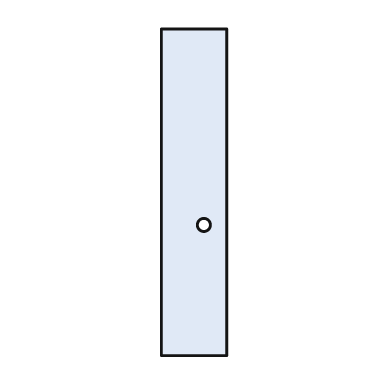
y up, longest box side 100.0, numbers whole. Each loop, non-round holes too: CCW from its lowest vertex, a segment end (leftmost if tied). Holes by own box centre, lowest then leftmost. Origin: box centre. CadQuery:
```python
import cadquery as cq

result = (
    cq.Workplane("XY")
    .moveTo(-10.0, -50.0)
    .lineTo(10.0, -50.0)
    .lineTo(10.0, 50.0)
    .lineTo(-10.0, 50.0)
    .close()
    .moveTo(3.0, -10.0)
    .circle(2.0)
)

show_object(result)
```